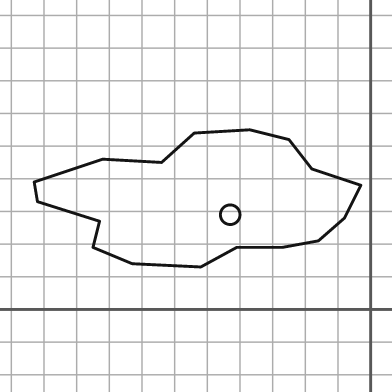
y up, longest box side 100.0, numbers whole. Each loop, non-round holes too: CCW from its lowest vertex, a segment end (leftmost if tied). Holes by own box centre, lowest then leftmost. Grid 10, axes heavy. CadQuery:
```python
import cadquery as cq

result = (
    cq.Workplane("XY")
    .moveTo(-52.0, 13.0)
    .lineTo(-41.0, 19.0)
    .lineTo(-27.0, 19.0)
    .lineTo(-16.0, 21.0)
    .lineTo(-8.0, 28.0)
    .lineTo(-3.0, 38.0)
    .lineTo(-18.0, 43.0)
    .lineTo(-25.0, 52.0)
    .lineTo(-37.0, 55.0)
    .lineTo(-54.0, 54.0)
    .lineTo(-64.0, 45.0)
    .lineTo(-82.0, 46.0)
    .lineTo(-103.0, 39.0)
    .lineTo(-102.0, 33.0)
    .lineTo(-83.0, 27.0)
    .lineTo(-85.0, 19.0)
    .lineTo(-73.0, 14.0)
    .close()
    .moveTo(-43.0, 29.0)
    .circle(3.0)
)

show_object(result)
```